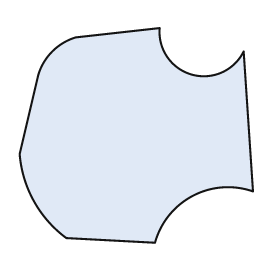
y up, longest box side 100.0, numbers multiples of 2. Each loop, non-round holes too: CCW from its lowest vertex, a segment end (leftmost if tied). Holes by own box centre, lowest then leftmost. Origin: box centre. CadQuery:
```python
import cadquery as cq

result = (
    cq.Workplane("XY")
    .moveTo(8.0, -46.0)
    .threePointArc((24.0, -26.0), (50.0, -24.0))
    .lineTo(46.0, 36.0)
    .threePointArc((24.0, 26.0), (10.0, 46.0))
    .lineTo(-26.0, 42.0)
    .threePointArc((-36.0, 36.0), (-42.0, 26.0))
    .lineTo(-50.0, -8.0)
    .threePointArc((-44.0, -28.0), (-30.0, -44.0))
    .close()
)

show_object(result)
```